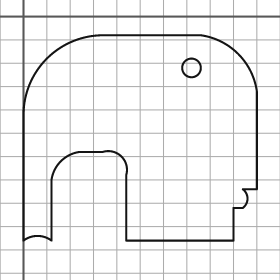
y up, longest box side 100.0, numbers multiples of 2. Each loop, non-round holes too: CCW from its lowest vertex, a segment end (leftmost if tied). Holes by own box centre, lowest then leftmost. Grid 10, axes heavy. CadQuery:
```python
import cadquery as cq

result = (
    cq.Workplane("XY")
    .moveTo(0.0, -96.0)
    .threePointArc((6.0, -94.0), (12.0, -96.0))
    .lineTo(12.0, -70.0)
    .threePointArc((16.0, -62.0), (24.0, -58.0))
    .lineTo(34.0, -58.0)
    .threePointArc((42.0, -60.0), (44.0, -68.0))
    .lineTo(44.0, -96.0)
    .lineTo(90.0, -96.0)
    .lineTo(90.0, -82.0)
    .lineTo(94.0, -82.0)
    .threePointArc((96.0, -78.0), (94.0, -74.0))
    .lineTo(100.0, -74.0)
    .lineTo(100.0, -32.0)
    .threePointArc((92.0, -16.0), (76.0, -8.0))
    .lineTo(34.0, -8.0)
    .threePointArc((10.0, -18.0), (0.0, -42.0))
    .close()
    .moveTo(72.0, -22.0)
    .circle(4.0)
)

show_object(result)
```